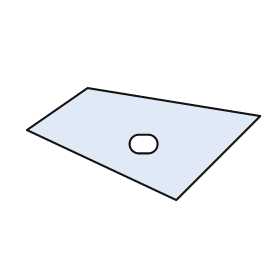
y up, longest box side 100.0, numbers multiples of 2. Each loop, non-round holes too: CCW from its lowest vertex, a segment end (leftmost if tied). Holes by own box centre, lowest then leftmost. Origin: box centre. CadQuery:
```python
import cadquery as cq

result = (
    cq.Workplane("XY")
    .moveTo(14.0, -24.0)
    .lineTo(50.0, 12.0)
    .lineTo(-24.0, 24.0)
    .lineTo(-50.0, 6.0)
    .close()
    .moveTo(-2.0, -4.0)
    .lineTo(2.0, -4.0)
    .threePointArc((6.0, 0.0), (2.0, 4.0))
    .lineTo(-2.0, 4.0)
    .threePointArc((-6.0, 0.0), (-2.0, -4.0))
    .close()
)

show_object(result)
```